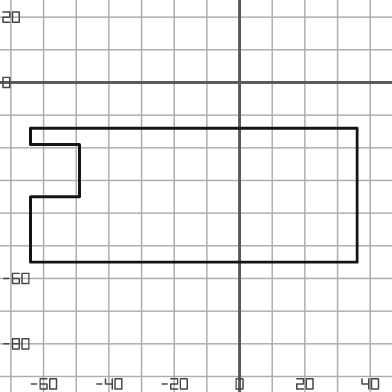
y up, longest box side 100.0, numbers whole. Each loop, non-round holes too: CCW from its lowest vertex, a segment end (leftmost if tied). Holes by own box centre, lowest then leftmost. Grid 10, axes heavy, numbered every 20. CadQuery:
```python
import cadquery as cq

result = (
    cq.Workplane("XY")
    .moveTo(-64.0, -55.0)
    .lineTo(36.0, -55.0)
    .lineTo(36.0, -14.0)
    .lineTo(-64.0, -14.0)
    .lineTo(-64.0, -19.0)
    .lineTo(-49.0, -19.0)
    .lineTo(-49.0, -35.0)
    .lineTo(-64.0, -35.0)
    .close()
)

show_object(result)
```